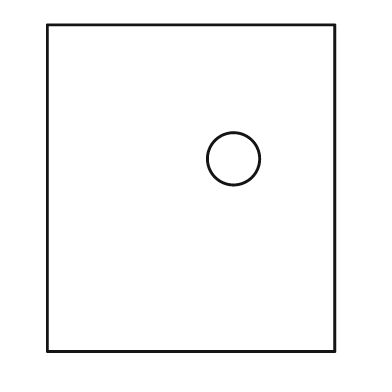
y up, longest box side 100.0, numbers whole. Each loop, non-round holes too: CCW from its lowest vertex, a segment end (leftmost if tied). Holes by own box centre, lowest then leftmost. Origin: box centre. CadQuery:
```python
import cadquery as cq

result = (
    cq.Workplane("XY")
    .moveTo(-44.0, -50.0)
    .lineTo(44.0, -50.0)
    .lineTo(44.0, 50.0)
    .lineTo(-44.0, 50.0)
    .close()
    .moveTo(13.0, 9.0)
    .circle(8.0)
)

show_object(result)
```